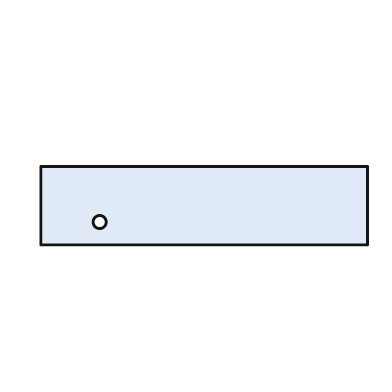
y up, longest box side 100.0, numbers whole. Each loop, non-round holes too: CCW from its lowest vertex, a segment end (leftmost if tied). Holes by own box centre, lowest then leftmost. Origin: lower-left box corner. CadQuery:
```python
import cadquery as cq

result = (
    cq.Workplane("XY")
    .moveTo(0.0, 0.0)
    .lineTo(100.0, 0.0)
    .lineTo(100.0, 24.0)
    .lineTo(0.0, 24.0)
    .close()
    .moveTo(18.0, 7.0)
    .circle(2.0)
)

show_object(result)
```